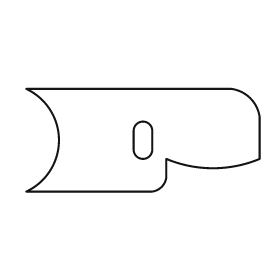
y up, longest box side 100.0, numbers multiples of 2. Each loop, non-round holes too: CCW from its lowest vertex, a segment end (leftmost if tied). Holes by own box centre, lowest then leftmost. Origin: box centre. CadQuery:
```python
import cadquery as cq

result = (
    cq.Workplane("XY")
    .moveTo(-50.0, -22.0)
    .lineTo(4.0, -22.0)
    .threePointArc((8.0, -20.0), (10.0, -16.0))
    .lineTo(10.0, -8.0)
    .threePointArc((30.0, -12.0), (50.0, -8.0))
    .lineTo(50.0, 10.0)
    .threePointArc((46.0, 18.0), (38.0, 22.0))
    .lineTo(-50.0, 22.0)
    .threePointArc((-36.0, 0.0), (-50.0, -22.0))
    .close()
    .moveTo(-4.0, -4.0)
    .threePointArc((0.0, -8.0), (4.0, -4.0))
    .lineTo(4.0, 4.0)
    .threePointArc((0.0, 8.0), (-4.0, 4.0))
    .close()
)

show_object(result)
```